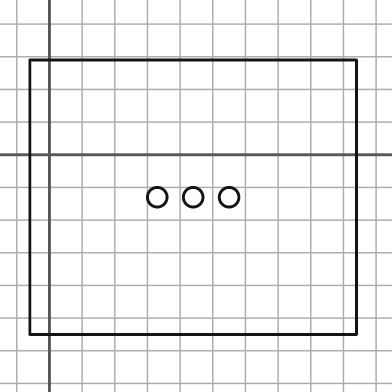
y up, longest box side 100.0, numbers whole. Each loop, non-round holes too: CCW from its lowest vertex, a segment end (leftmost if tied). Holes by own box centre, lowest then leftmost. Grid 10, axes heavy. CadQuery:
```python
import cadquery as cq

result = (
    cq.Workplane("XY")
    .moveTo(-6.0, -55.0)
    .lineTo(94.0, -55.0)
    .lineTo(94.0, 29.0)
    .lineTo(-6.0, 29.0)
    .close()
    .moveTo(33.0, -13.0)
    .circle(3.0)
    .moveTo(44.0, -13.0)
    .circle(3.0)
    .moveTo(55.0, -13.0)
    .circle(3.0)
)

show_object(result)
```